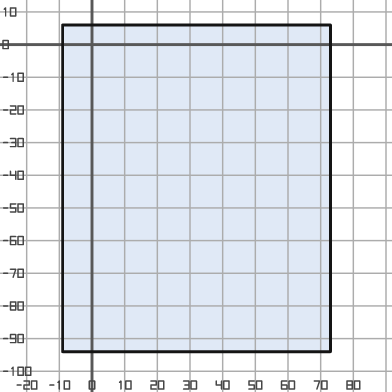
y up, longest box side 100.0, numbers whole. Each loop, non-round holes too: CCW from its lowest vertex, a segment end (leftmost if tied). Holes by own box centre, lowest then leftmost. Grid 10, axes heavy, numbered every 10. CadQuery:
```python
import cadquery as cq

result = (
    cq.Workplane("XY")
    .moveTo(-9.0, -94.0)
    .lineTo(73.0, -94.0)
    .lineTo(73.0, 6.0)
    .lineTo(-9.0, 6.0)
    .close()
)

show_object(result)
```